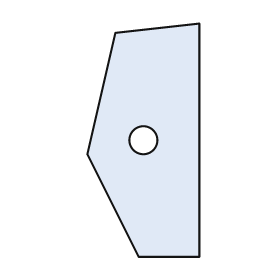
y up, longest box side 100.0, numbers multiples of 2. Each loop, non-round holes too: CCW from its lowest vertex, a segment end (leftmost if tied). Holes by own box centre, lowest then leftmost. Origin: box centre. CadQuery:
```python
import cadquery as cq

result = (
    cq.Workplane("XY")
    .moveTo(-2.0, -50.0)
    .lineTo(24.0, -50.0)
    .lineTo(24.0, 50.0)
    .lineTo(-12.0, 46.0)
    .lineTo(-24.0, -6.0)
    .close()
    .moveTo(0.0, 0.0)
    .circle(6.0)
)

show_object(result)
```